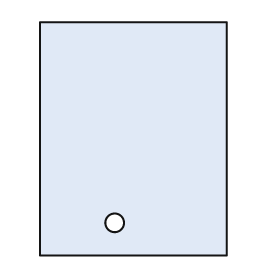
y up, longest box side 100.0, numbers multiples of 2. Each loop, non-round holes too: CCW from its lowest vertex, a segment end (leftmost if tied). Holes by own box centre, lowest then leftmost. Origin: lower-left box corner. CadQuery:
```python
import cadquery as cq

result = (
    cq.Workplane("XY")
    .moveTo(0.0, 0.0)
    .lineTo(80.0, 0.0)
    .lineTo(80.0, 100.0)
    .lineTo(0.0, 100.0)
    .close()
    .moveTo(32.0, 14.0)
    .circle(4.0)
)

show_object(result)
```